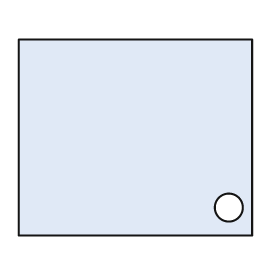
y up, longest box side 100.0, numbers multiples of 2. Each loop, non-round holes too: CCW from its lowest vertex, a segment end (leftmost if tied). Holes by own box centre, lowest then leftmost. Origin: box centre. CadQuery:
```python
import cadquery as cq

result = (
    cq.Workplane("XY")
    .moveTo(-50.0, -42.0)
    .lineTo(50.0, -42.0)
    .lineTo(50.0, 42.0)
    .lineTo(-50.0, 42.0)
    .close()
    .moveTo(40.0, -30.0)
    .circle(6.0)
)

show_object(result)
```